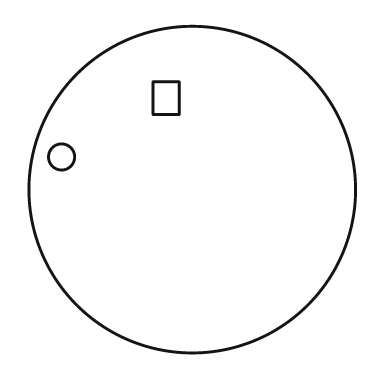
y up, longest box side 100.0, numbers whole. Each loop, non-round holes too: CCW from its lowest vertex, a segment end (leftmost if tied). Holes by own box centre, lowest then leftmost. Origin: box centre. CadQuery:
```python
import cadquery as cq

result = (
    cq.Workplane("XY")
    .moveTo(0.0, 0.0)
    .circle(50.0)
    .moveTo(-40.0, 10.0)
    .circle(4.0)
    .moveTo(-12.0, 23.0)
    .lineTo(-4.0, 23.0)
    .lineTo(-4.0, 33.0)
    .lineTo(-12.0, 33.0)
    .close()
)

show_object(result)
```